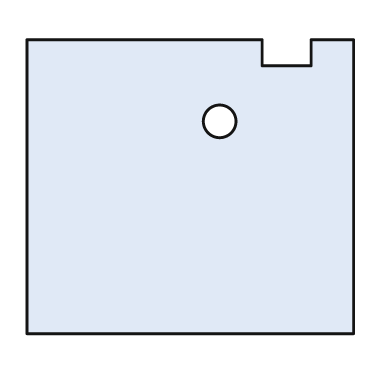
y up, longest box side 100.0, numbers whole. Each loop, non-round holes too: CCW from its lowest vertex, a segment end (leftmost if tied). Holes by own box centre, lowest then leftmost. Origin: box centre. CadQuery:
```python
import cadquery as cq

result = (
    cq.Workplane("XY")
    .moveTo(-50.0, -45.0)
    .lineTo(50.0, -45.0)
    .lineTo(50.0, 45.0)
    .lineTo(37.0, 45.0)
    .lineTo(37.0, 37.0)
    .lineTo(22.0, 37.0)
    .lineTo(22.0, 45.0)
    .lineTo(-50.0, 45.0)
    .close()
    .moveTo(9.0, 20.0)
    .circle(5.0)
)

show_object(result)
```